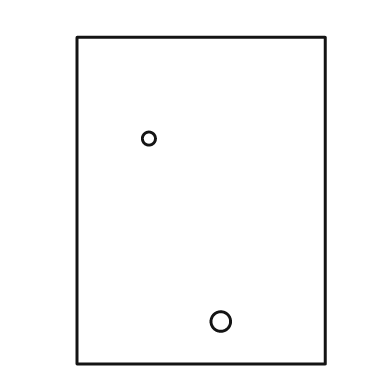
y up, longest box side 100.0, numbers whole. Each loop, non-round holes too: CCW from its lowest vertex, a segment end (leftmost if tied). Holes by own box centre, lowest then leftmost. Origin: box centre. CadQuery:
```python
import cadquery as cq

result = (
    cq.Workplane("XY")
    .moveTo(-38.0, -50.0)
    .lineTo(38.0, -50.0)
    .lineTo(38.0, 50.0)
    .lineTo(-38.0, 50.0)
    .close()
    .moveTo(6.0, -37.0)
    .circle(3.0)
    .moveTo(-16.0, 19.0)
    .circle(2.0)
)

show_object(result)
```